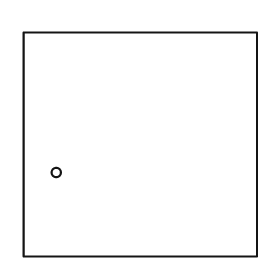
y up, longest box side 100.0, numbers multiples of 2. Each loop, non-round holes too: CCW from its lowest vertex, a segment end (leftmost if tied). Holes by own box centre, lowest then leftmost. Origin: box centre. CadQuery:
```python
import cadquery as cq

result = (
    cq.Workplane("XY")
    .moveTo(-50.0, -48.0)
    .lineTo(50.0, -48.0)
    .lineTo(50.0, 48.0)
    .lineTo(-50.0, 48.0)
    .close()
    .moveTo(-36.0, -12.0)
    .circle(2.0)
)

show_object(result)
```